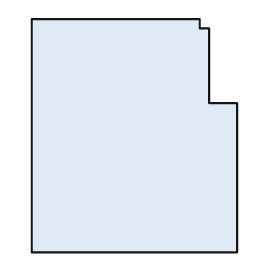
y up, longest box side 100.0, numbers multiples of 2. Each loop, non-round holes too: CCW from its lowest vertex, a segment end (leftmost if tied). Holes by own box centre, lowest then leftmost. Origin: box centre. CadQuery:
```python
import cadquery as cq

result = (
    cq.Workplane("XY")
    .moveTo(-44.0, -50.0)
    .lineTo(44.0, -50.0)
    .lineTo(44.0, 14.0)
    .lineTo(32.0, 14.0)
    .lineTo(32.0, 46.0)
    .lineTo(28.0, 46.0)
    .lineTo(28.0, 50.0)
    .lineTo(-44.0, 50.0)
    .close()
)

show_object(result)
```